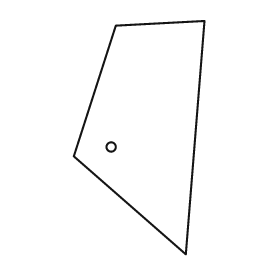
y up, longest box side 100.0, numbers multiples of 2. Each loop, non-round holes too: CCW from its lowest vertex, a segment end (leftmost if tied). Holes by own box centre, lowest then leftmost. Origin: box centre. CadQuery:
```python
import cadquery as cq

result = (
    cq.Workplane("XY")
    .moveTo(20.0, -50.0)
    .lineTo(28.0, 50.0)
    .lineTo(-10.0, 48.0)
    .lineTo(-28.0, -8.0)
    .close()
    .moveTo(-12.0, -4.0)
    .circle(2.0)
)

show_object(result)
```